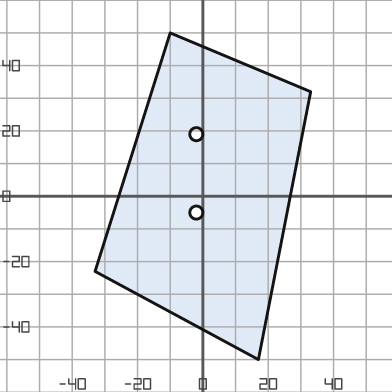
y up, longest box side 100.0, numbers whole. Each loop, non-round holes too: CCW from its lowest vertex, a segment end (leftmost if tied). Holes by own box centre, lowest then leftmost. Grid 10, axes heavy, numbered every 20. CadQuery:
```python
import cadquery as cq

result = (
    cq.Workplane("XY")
    .moveTo(17.0, -50.0)
    .lineTo(33.0, 32.0)
    .lineTo(-10.0, 50.0)
    .lineTo(-33.0, -23.0)
    .close()
    .moveTo(-2.0, -5.0)
    .circle(2.0)
    .moveTo(-2.0, 19.0)
    .circle(2.0)
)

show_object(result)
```